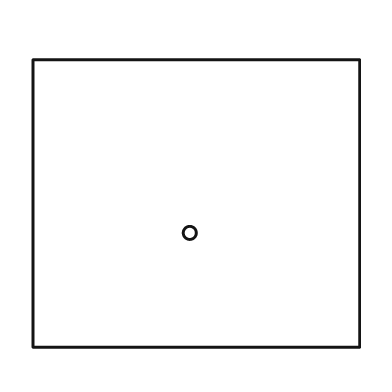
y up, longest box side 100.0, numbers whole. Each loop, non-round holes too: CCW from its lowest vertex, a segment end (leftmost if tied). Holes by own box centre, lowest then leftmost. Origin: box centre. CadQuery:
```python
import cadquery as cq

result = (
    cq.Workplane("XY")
    .moveTo(-50.0, -44.0)
    .lineTo(50.0, -44.0)
    .lineTo(50.0, 44.0)
    .lineTo(-50.0, 44.0)
    .close()
    .moveTo(-2.0, -9.0)
    .circle(2.0)
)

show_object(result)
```